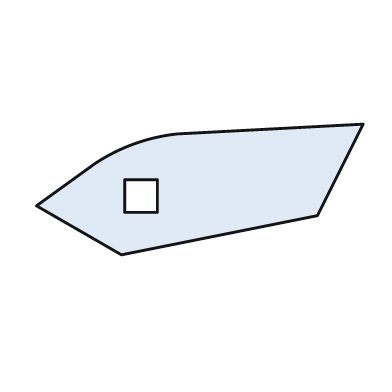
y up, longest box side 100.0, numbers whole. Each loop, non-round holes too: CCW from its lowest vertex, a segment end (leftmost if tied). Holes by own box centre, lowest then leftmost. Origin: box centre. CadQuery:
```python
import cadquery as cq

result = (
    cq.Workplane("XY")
    .moveTo(-24.0, -20.0)
    .lineTo(36.0, -8.0)
    .lineTo(50.0, 20.0)
    .lineTo(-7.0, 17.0)
    .threePointArc((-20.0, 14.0), (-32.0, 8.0))
    .lineTo(-50.0, -5.0)
    .close()
    .moveTo(-23.0, -7.0)
    .lineTo(-13.0, -7.0)
    .lineTo(-13.0, 3.0)
    .lineTo(-23.0, 3.0)
    .close()
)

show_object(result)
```